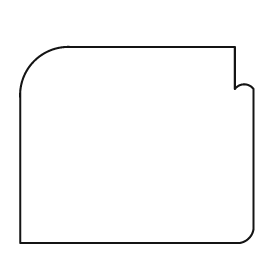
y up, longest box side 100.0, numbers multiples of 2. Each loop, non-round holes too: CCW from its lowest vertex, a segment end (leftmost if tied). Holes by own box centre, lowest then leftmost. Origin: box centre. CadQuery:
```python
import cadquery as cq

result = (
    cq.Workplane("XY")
    .moveTo(-50.0, -42.0)
    .lineTo(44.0, -42.0)
    .threePointArc((48.0, -40.0), (50.0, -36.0))
    .lineTo(50.0, 24.0)
    .threePointArc((46.0, 26.0), (42.0, 24.0))
    .lineTo(42.0, 42.0)
    .lineTo(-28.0, 42.0)
    .threePointArc((-44.0, 36.0), (-50.0, 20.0))
    .close()
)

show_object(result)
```